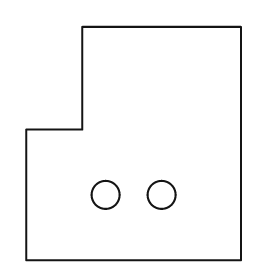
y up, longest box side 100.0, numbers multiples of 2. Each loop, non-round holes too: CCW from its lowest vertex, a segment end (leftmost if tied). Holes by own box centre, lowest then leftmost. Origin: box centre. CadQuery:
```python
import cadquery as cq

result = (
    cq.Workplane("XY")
    .moveTo(-46.0, -50.0)
    .lineTo(46.0, -50.0)
    .lineTo(46.0, 50.0)
    .lineTo(-22.0, 50.0)
    .lineTo(-22.0, 6.0)
    .lineTo(-46.0, 6.0)
    .close()
    .moveTo(-12.0, -22.0)
    .circle(6.0)
    .moveTo(12.0, -22.0)
    .circle(6.0)
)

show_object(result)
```